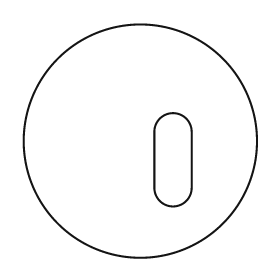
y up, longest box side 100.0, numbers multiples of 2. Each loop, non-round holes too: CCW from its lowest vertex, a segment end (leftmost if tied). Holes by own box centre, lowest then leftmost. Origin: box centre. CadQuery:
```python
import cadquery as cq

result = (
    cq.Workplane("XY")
    .moveTo(0.0, 0.0)
    .circle(50.0)
    .moveTo(6.0, -20.0)
    .threePointArc((14.0, -28.0), (22.0, -20.0))
    .lineTo(22.0, 4.0)
    .threePointArc((14.0, 12.0), (6.0, 4.0))
    .close()
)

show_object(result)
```